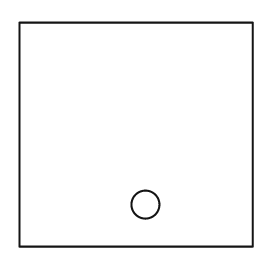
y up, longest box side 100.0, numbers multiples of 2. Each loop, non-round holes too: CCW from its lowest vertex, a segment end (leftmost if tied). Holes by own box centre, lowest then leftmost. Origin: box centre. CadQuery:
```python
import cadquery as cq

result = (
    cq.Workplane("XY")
    .moveTo(-50.0, -48.0)
    .lineTo(50.0, -48.0)
    .lineTo(50.0, 48.0)
    .lineTo(-50.0, 48.0)
    .close()
    .moveTo(4.0, -30.0)
    .circle(6.0)
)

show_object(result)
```